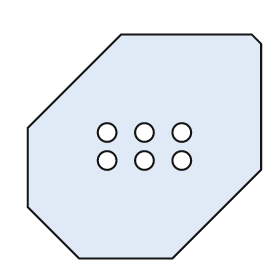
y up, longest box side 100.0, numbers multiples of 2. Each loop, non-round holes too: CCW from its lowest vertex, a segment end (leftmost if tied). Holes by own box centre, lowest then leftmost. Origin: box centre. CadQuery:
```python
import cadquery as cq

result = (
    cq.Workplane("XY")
    .moveTo(-28.0, -48.0)
    .lineTo(12.0, -48.0)
    .lineTo(50.0, -10.0)
    .lineTo(50.0, 44.0)
    .lineTo(46.0, 48.0)
    .lineTo(-10.0, 48.0)
    .lineTo(-50.0, 8.0)
    .lineTo(-50.0, -26.0)
    .close()
    .moveTo(-16.0, -6.0)
    .circle(4.0)
    .moveTo(0.0, -6.0)
    .circle(4.0)
    .moveTo(16.0, -6.0)
    .circle(4.0)
    .moveTo(-16.0, 6.0)
    .circle(4.0)
    .moveTo(0.0, 6.0)
    .circle(4.0)
    .moveTo(16.0, 6.0)
    .circle(4.0)
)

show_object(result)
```